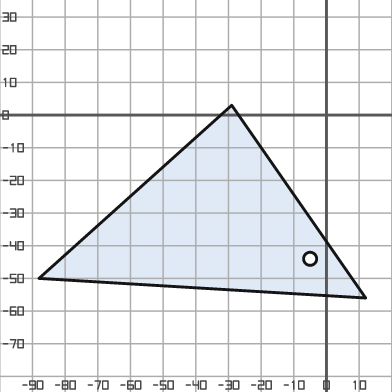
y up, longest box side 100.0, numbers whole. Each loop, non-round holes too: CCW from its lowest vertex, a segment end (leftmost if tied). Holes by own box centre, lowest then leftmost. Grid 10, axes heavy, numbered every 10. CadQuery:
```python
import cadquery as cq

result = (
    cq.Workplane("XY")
    .moveTo(12.0, -56.0)
    .lineTo(-29.0, 3.0)
    .lineTo(-88.0, -50.0)
    .close()
    .moveTo(-5.0, -44.0)
    .circle(2.0)
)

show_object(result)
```